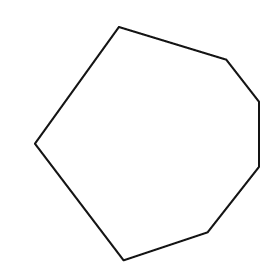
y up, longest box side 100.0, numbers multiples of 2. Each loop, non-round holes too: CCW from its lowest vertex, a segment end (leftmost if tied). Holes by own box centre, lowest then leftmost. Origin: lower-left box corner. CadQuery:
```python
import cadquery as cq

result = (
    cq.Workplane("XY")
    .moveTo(38.0, 0.0)
    .lineTo(74.0, 12.0)
    .lineTo(96.0, 40.0)
    .lineTo(96.0, 68.0)
    .lineTo(82.0, 86.0)
    .lineTo(36.0, 100.0)
    .lineTo(0.0, 50.0)
    .close()
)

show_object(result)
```